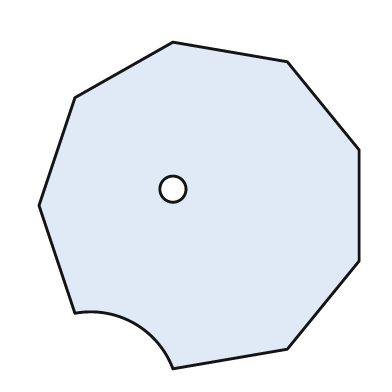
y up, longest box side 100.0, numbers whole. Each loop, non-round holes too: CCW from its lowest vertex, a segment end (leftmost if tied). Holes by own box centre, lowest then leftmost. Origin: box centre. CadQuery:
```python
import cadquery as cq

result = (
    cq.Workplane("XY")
    .moveTo(-8.0, -50.0)
    .lineTo(27.0, -44.0)
    .lineTo(49.0, -17.0)
    .lineTo(49.0, 17.0)
    .lineTo(27.0, 44.0)
    .lineTo(-8.0, 50.0)
    .lineTo(-38.0, 33.0)
    .lineTo(-49.0, 0.0)
    .lineTo(-38.0, -33.0)
    .threePointArc((-20.0, -36.0), (-8.0, -50.0))
    .close()
    .moveTo(-8.0, 5.0)
    .circle(4.0)
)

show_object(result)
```